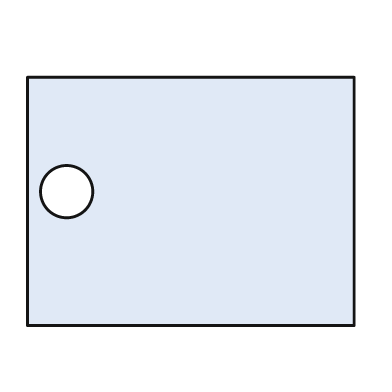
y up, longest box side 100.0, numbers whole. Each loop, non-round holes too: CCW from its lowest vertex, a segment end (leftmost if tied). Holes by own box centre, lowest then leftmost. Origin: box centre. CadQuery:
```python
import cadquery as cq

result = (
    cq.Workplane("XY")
    .moveTo(-50.0, -38.0)
    .lineTo(50.0, -38.0)
    .lineTo(50.0, 38.0)
    .lineTo(-50.0, 38.0)
    .close()
    .moveTo(-38.0, 3.0)
    .circle(8.0)
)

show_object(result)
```